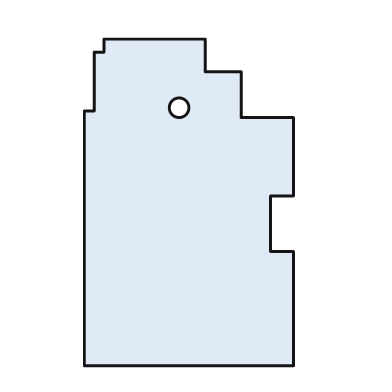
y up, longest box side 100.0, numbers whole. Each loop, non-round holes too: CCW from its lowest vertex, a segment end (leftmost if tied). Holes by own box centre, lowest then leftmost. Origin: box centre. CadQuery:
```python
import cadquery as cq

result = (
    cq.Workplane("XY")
    .moveTo(-32.0, -50.0)
    .lineTo(32.0, -50.0)
    .lineTo(32.0, -15.0)
    .lineTo(25.0, -15.0)
    .lineTo(25.0, 2.0)
    .lineTo(32.0, 2.0)
    .lineTo(32.0, 26.0)
    .lineTo(16.0, 26.0)
    .lineTo(16.0, 40.0)
    .lineTo(5.0, 40.0)
    .lineTo(5.0, 50.0)
    .lineTo(-26.0, 50.0)
    .lineTo(-26.0, 46.0)
    .lineTo(-29.0, 46.0)
    .lineTo(-29.0, 28.0)
    .lineTo(-32.0, 28.0)
    .close()
    .moveTo(-3.0, 29.0)
    .circle(3.0)
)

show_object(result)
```